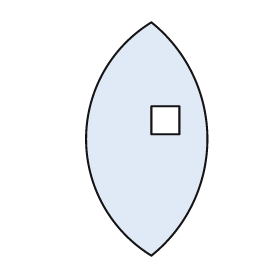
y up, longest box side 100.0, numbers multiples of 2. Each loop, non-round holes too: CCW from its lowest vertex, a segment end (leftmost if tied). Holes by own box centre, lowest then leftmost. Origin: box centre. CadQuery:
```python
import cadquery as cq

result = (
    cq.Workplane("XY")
    .moveTo(2.0, -50.0)
    .threePointArc((26.0, 0.0), (2.0, 50.0))
    .threePointArc((-26.0, 0.0), (2.0, -50.0))
    .close()
    .moveTo(2.0, 2.0)
    .lineTo(14.0, 2.0)
    .lineTo(14.0, 14.0)
    .lineTo(2.0, 14.0)
    .close()
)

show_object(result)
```